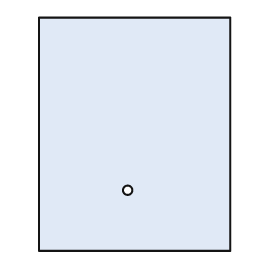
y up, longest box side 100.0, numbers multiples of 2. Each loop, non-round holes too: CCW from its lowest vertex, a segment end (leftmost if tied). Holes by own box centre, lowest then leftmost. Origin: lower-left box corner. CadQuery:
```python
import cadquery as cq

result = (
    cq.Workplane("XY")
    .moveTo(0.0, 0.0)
    .lineTo(82.0, 0.0)
    .lineTo(82.0, 100.0)
    .lineTo(0.0, 100.0)
    .close()
    .moveTo(38.0, 26.0)
    .circle(2.0)
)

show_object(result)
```